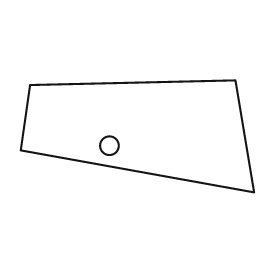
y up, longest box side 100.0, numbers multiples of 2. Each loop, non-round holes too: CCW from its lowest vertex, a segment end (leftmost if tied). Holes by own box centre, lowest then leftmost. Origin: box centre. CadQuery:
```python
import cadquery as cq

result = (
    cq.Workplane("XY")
    .moveTo(50.0, -24.0)
    .lineTo(42.0, 24.0)
    .lineTo(-46.0, 22.0)
    .lineTo(-50.0, -6.0)
    .close()
    .moveTo(-12.0, -4.0)
    .circle(4.0)
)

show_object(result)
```